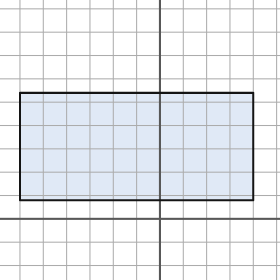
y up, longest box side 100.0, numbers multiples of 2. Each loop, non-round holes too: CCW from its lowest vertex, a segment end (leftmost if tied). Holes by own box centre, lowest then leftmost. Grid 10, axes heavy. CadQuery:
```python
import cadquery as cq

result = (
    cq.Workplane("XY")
    .moveTo(-60.0, 8.0)
    .lineTo(40.0, 8.0)
    .lineTo(40.0, 54.0)
    .lineTo(-60.0, 54.0)
    .close()
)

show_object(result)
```